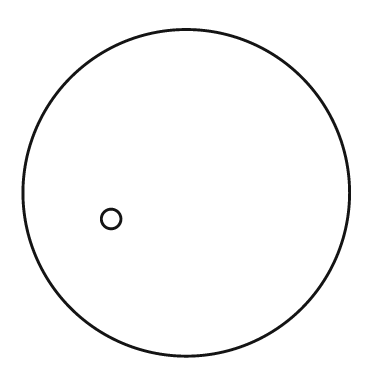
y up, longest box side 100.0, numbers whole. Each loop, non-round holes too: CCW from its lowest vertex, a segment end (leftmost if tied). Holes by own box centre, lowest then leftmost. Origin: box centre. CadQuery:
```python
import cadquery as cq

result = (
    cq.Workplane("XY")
    .moveTo(0.0, 0.0)
    .circle(50.0)
    .moveTo(-23.0, -8.0)
    .circle(3.0)
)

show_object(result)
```